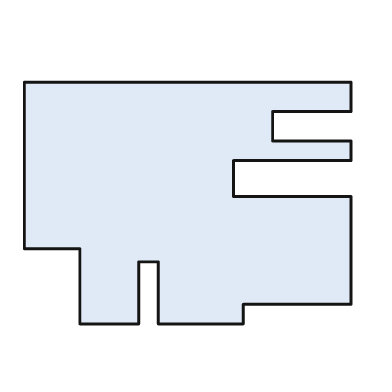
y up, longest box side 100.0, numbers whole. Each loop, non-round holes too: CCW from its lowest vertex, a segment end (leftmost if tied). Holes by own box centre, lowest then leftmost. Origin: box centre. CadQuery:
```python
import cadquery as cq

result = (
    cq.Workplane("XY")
    .moveTo(-33.0, -37.0)
    .lineTo(-15.0, -37.0)
    .lineTo(-15.0, -18.0)
    .lineTo(-9.0, -18.0)
    .lineTo(-9.0, -37.0)
    .lineTo(17.0, -37.0)
    .lineTo(17.0, -31.0)
    .lineTo(50.0, -31.0)
    .lineTo(50.0, 2.0)
    .lineTo(14.0, 2.0)
    .lineTo(14.0, 13.0)
    .lineTo(50.0, 13.0)
    .lineTo(50.0, 19.0)
    .lineTo(26.0, 19.0)
    .lineTo(26.0, 28.0)
    .lineTo(50.0, 28.0)
    .lineTo(50.0, 37.0)
    .lineTo(-50.0, 37.0)
    .lineTo(-50.0, -14.0)
    .lineTo(-33.0, -14.0)
    .close()
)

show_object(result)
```